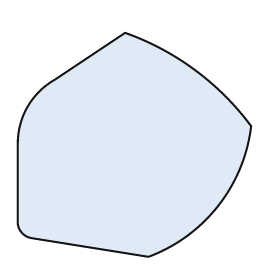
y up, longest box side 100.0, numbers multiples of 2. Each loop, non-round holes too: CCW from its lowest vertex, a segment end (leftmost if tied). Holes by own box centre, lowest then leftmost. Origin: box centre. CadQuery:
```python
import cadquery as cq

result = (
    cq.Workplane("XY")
    .moveTo(6.0, -48.0)
    .threePointArc((36.0, -26.0), (50.0, 8.0))
    .threePointArc((26.0, 32.0), (-4.0, 48.0))
    .lineTo(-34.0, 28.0)
    .threePointArc((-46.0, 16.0), (-50.0, 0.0))
    .lineTo(-50.0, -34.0)
    .threePointArc((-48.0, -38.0), (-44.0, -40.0))
    .close()
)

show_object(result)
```